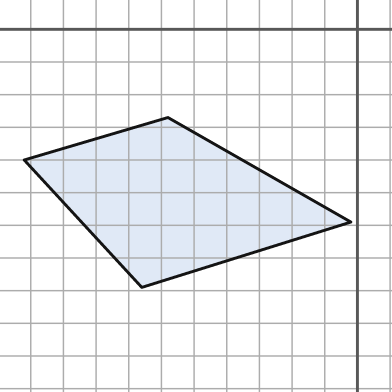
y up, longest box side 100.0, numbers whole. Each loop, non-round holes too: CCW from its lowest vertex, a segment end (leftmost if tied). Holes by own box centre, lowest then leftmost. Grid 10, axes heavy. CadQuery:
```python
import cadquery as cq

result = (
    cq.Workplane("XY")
    .moveTo(-66.0, -79.0)
    .lineTo(-2.0, -59.0)
    .lineTo(-58.0, -27.0)
    .lineTo(-102.0, -40.0)
    .close()
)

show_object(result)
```